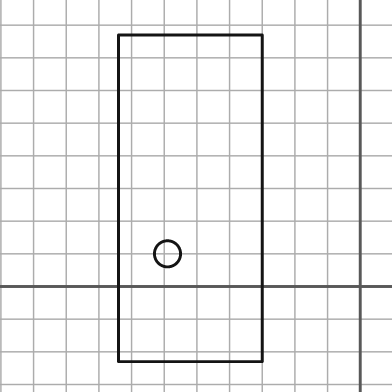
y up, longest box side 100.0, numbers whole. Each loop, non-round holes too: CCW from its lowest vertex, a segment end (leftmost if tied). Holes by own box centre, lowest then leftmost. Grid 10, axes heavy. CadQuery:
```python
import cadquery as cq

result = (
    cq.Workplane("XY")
    .moveTo(-74.0, -23.0)
    .lineTo(-30.0, -23.0)
    .lineTo(-30.0, 77.0)
    .lineTo(-74.0, 77.0)
    .close()
    .moveTo(-59.0, 10.0)
    .circle(4.0)
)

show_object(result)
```